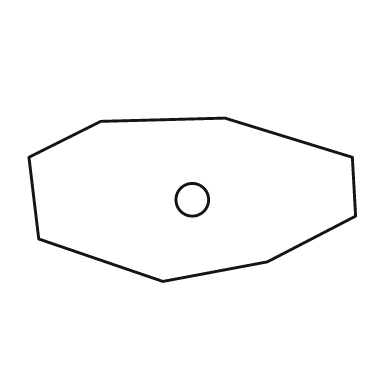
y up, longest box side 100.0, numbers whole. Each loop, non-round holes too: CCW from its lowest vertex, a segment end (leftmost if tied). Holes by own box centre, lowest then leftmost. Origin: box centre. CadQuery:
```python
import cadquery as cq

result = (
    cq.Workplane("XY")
    .moveTo(-9.0, -25.0)
    .lineTo(23.0, -19.0)
    .lineTo(50.0, -5.0)
    .lineTo(49.0, 13.0)
    .lineTo(10.0, 25.0)
    .lineTo(-28.0, 24.0)
    .lineTo(-50.0, 13.0)
    .lineTo(-47.0, -12.0)
    .close()
    .moveTo(0.0, 0.0)
    .circle(5.0)
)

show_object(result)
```